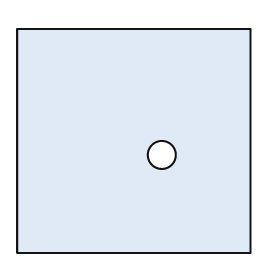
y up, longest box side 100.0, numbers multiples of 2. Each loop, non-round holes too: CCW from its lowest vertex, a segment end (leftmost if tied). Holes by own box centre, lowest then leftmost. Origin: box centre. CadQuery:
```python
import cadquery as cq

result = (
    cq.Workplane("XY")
    .moveTo(-50.0, -48.0)
    .lineTo(50.0, -48.0)
    .lineTo(50.0, 48.0)
    .lineTo(-50.0, 48.0)
    .close()
    .moveTo(12.0, -6.0)
    .circle(6.0)
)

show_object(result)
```